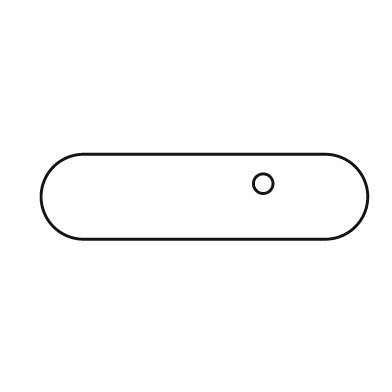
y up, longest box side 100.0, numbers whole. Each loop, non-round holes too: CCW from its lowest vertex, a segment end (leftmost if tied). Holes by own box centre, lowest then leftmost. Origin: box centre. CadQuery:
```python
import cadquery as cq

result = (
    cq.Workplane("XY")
    .moveTo(-37.0, -13.0)
    .lineTo(37.0, -13.0)
    .threePointArc((50.0, 0.0), (37.0, 13.0))
    .lineTo(-37.0, 13.0)
    .threePointArc((-50.0, 0.0), (-37.0, -13.0))
    .close()
    .moveTo(18.0, 4.0)
    .circle(3.0)
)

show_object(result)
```